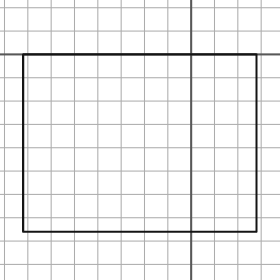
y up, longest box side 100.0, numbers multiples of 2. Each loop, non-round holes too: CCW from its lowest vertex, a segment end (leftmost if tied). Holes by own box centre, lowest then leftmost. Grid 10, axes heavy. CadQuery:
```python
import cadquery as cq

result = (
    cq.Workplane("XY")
    .moveTo(-72.0, -76.0)
    .lineTo(28.0, -76.0)
    .lineTo(28.0, 0.0)
    .lineTo(-72.0, 0.0)
    .close()
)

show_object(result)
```